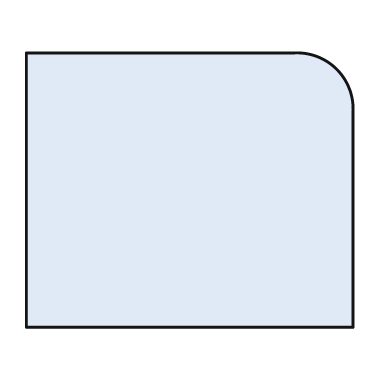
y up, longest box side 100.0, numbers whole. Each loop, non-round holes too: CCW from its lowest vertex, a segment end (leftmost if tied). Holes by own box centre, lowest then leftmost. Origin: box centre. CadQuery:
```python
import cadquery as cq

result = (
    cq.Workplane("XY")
    .moveTo(-50.0, -42.0)
    .lineTo(50.0, -42.0)
    .lineTo(50.0, 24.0)
    .threePointArc((45.0, 37.0), (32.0, 42.0))
    .lineTo(-50.0, 42.0)
    .close()
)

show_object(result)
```